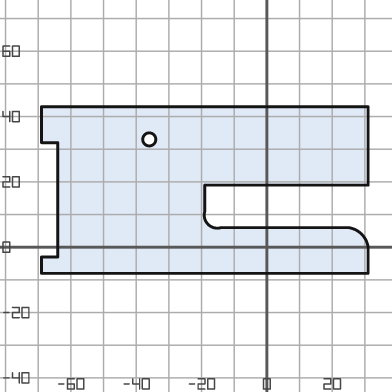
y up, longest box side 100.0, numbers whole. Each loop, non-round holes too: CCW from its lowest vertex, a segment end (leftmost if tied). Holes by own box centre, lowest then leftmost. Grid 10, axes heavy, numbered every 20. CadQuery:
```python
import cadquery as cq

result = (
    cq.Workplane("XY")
    .moveTo(-69.0, -8.0)
    .lineTo(31.0, -8.0)
    .lineTo(31.0, 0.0)
    .threePointArc((29.0, 4.0), (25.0, 6.0))
    .lineTo(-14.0, 6.0)
    .threePointArc((-18.0, 7.0), (-19.0, 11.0))
    .lineTo(-19.0, 19.0)
    .lineTo(31.0, 19.0)
    .lineTo(31.0, 43.0)
    .lineTo(-69.0, 43.0)
    .lineTo(-69.0, 32.0)
    .lineTo(-64.0, 32.0)
    .lineTo(-64.0, -3.0)
    .lineTo(-69.0, -3.0)
    .close()
    .moveTo(-36.0, 33.0)
    .circle(2.0)
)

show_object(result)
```